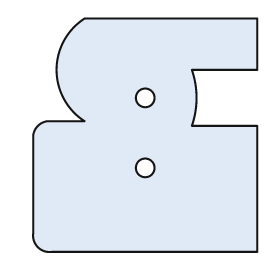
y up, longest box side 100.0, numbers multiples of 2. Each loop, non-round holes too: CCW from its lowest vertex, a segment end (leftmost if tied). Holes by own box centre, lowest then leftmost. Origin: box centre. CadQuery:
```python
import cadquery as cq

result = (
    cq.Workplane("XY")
    .moveTo(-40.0, -50.0)
    .lineTo(48.0, -50.0)
    .lineTo(48.0, 4.0)
    .lineTo(20.0, 4.0)
    .threePointArc((22.0, 16.0), (20.0, 28.0))
    .lineTo(48.0, 28.0)
    .lineTo(48.0, 50.0)
    .lineTo(-26.0, 50.0)
    .threePointArc((-38.0, 28.0), (-26.0, 6.0))
    .lineTo(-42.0, 6.0)
    .threePointArc((-46.0, 4.0), (-48.0, 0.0))
    .lineTo(-48.0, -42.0)
    .threePointArc((-46.0, -48.0), (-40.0, -50.0))
    .close()
    .moveTo(0.0, -14.0)
    .circle(4.0)
    .moveTo(0.0, 16.0)
    .circle(4.0)
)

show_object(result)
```